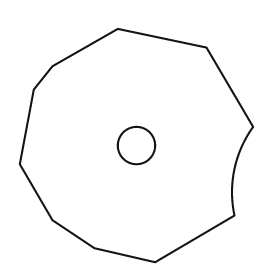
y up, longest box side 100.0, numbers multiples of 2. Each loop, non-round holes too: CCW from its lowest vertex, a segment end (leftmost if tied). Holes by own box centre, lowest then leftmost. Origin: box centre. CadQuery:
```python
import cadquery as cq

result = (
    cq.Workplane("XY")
    .moveTo(8.0, -50.0)
    .lineTo(42.0, -30.0)
    .threePointArc((42.0, -10.0), (50.0, 8.0))
    .lineTo(30.0, 42.0)
    .lineTo(-8.0, 50.0)
    .lineTo(-36.0, 34.0)
    .lineTo(-44.0, 24.0)
    .lineTo(-50.0, -8.0)
    .lineTo(-36.0, -32.0)
    .lineTo(-18.0, -44.0)
    .close()
    .moveTo(0.0, 0.0)
    .circle(8.0)
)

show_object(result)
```